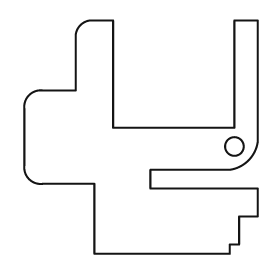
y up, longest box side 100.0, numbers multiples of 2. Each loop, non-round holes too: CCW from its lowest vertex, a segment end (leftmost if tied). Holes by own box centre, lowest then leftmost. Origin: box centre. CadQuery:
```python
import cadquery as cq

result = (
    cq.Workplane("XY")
    .moveTo(-20.0, -50.0)
    .lineTo(38.0, -50.0)
    .lineTo(38.0, -46.0)
    .lineTo(42.0, -46.0)
    .lineTo(42.0, -34.0)
    .lineTo(50.0, -34.0)
    .lineTo(50.0, -22.0)
    .lineTo(4.0, -22.0)
    .lineTo(4.0, -14.0)
    .lineTo(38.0, -14.0)
    .threePointArc((46.0, -10.0), (50.0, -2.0))
    .lineTo(50.0, 50.0)
    .lineTo(40.0, 50.0)
    .lineTo(40.0, 4.0)
    .lineTo(-12.0, 4.0)
    .lineTo(-12.0, 50.0)
    .lineTo(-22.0, 50.0)
    .threePointArc((-26.0, 48.0), (-28.0, 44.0))
    .lineTo(-28.0, 20.0)
    .lineTo(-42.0, 20.0)
    .threePointArc((-48.0, 18.0), (-50.0, 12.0))
    .lineTo(-50.0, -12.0)
    .threePointArc((-48.0, -18.0), (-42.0, -20.0))
    .lineTo(-20.0, -20.0)
    .close()
    .moveTo(40.0, -4.0)
    .circle(4.0)
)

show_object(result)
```